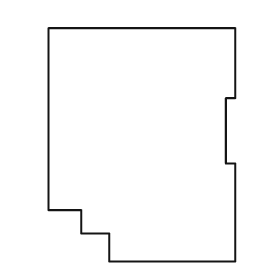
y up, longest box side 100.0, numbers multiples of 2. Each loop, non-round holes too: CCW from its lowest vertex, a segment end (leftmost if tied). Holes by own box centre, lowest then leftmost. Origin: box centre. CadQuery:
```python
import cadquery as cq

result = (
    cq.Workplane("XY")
    .moveTo(-14.0, -50.0)
    .lineTo(40.0, -50.0)
    .lineTo(40.0, -8.0)
    .lineTo(36.0, -8.0)
    .lineTo(36.0, 20.0)
    .lineTo(40.0, 20.0)
    .lineTo(40.0, 50.0)
    .lineTo(-40.0, 50.0)
    .lineTo(-40.0, -28.0)
    .lineTo(-26.0, -28.0)
    .lineTo(-26.0, -38.0)
    .lineTo(-14.0, -38.0)
    .close()
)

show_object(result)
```